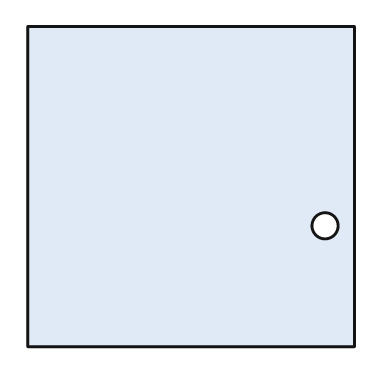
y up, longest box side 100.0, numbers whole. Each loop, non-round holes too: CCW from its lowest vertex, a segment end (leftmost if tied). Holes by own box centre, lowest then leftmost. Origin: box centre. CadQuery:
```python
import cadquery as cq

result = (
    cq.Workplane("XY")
    .moveTo(-50.0, -49.0)
    .lineTo(50.0, -49.0)
    .lineTo(50.0, 49.0)
    .lineTo(-50.0, 49.0)
    .close()
    .moveTo(41.0, -12.0)
    .circle(4.0)
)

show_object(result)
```